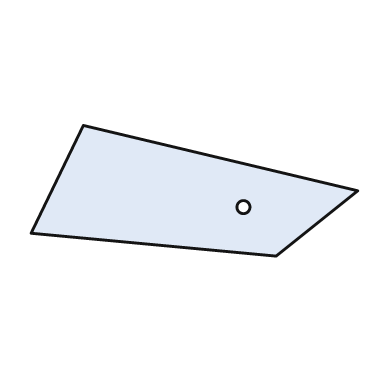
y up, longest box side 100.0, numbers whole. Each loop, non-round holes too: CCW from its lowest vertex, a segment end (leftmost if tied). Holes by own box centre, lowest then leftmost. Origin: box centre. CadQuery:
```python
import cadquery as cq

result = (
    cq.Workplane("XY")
    .moveTo(25.0, -20.0)
    .lineTo(50.0, 0.0)
    .lineTo(-34.0, 20.0)
    .lineTo(-50.0, -13.0)
    .close()
    .moveTo(15.0, -5.0)
    .circle(2.0)
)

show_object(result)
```